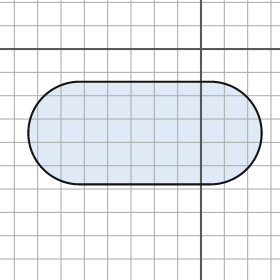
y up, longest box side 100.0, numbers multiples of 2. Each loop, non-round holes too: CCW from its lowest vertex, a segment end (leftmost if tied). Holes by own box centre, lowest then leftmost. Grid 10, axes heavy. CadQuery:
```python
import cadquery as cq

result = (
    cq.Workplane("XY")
    .moveTo(-52.0, -58.0)
    .lineTo(4.0, -58.0)
    .threePointArc((26.0, -36.0), (4.0, -14.0))
    .lineTo(-52.0, -14.0)
    .threePointArc((-74.0, -36.0), (-52.0, -58.0))
    .close()
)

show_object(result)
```